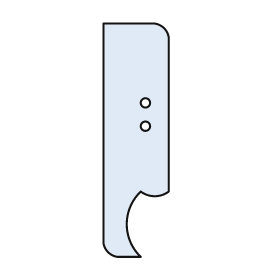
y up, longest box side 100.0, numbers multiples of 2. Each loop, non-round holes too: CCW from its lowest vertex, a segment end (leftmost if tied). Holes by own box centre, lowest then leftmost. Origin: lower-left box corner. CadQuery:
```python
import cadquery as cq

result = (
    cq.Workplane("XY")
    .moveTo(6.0, 0.0)
    .lineTo(16.0, 0.0)
    .threePointArc((10.0, 14.0), (16.0, 28.0))
    .threePointArc((22.0, 26.0), (28.0, 28.0))
    .lineTo(28.0, 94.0)
    .threePointArc((26.0, 98.0), (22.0, 100.0))
    .lineTo(0.0, 100.0)
    .lineTo(0.0, 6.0)
    .threePointArc((2.0, 2.0), (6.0, 0.0))
    .close()
    .moveTo(18.0, 56.0)
    .circle(2.0)
    .moveTo(18.0, 66.0)
    .circle(2.0)
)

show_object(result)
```